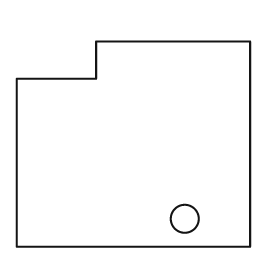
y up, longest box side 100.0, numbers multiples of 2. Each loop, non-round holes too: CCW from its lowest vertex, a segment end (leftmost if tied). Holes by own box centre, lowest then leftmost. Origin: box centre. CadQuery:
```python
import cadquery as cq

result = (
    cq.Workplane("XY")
    .moveTo(-50.0, -44.0)
    .lineTo(50.0, -44.0)
    .lineTo(50.0, 44.0)
    .lineTo(-16.0, 44.0)
    .lineTo(-16.0, 28.0)
    .lineTo(-50.0, 28.0)
    .close()
    .moveTo(22.0, -32.0)
    .circle(6.0)
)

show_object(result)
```